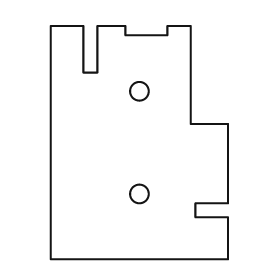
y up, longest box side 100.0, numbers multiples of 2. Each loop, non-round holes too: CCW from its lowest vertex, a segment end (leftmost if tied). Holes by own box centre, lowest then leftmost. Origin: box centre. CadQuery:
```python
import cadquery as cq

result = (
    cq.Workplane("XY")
    .moveTo(-38.0, -50.0)
    .lineTo(38.0, -50.0)
    .lineTo(38.0, -32.0)
    .lineTo(24.0, -32.0)
    .lineTo(24.0, -26.0)
    .lineTo(38.0, -26.0)
    .lineTo(38.0, 8.0)
    .lineTo(22.0, 8.0)
    .lineTo(22.0, 50.0)
    .lineTo(12.0, 50.0)
    .lineTo(12.0, 46.0)
    .lineTo(-6.0, 46.0)
    .lineTo(-6.0, 50.0)
    .lineTo(-18.0, 50.0)
    .lineTo(-18.0, 30.0)
    .lineTo(-24.0, 30.0)
    .lineTo(-24.0, 50.0)
    .lineTo(-38.0, 50.0)
    .close()
    .moveTo(0.0, -22.0)
    .circle(4.0)
    .moveTo(0.0, 22.0)
    .circle(4.0)
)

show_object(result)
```